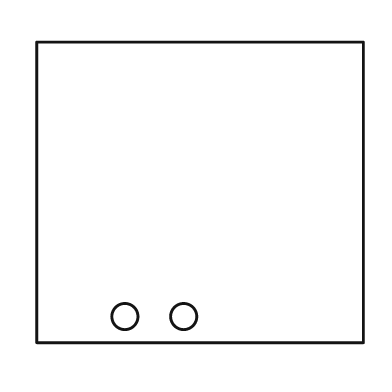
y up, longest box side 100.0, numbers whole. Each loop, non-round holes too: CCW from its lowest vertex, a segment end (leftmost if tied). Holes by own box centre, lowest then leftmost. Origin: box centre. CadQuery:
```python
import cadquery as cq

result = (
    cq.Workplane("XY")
    .moveTo(-50.0, -46.0)
    .lineTo(50.0, -46.0)
    .lineTo(50.0, 46.0)
    .lineTo(-50.0, 46.0)
    .close()
    .moveTo(-23.0, -38.0)
    .circle(4.0)
    .moveTo(-5.0, -38.0)
    .circle(4.0)
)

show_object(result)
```